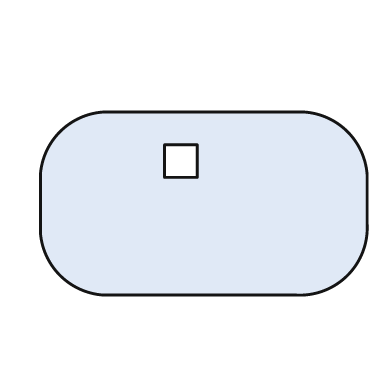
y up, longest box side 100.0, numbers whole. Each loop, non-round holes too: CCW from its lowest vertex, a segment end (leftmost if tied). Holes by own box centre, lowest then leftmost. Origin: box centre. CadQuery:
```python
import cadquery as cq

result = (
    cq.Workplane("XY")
    .moveTo(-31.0, -28.0)
    .lineTo(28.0, -28.0)
    .threePointArc((44.0, -22.0), (50.0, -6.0))
    .lineTo(50.0, 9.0)
    .threePointArc((44.0, 22.0), (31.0, 28.0))
    .lineTo(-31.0, 28.0)
    .threePointArc((-44.0, 22.0), (-50.0, 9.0))
    .lineTo(-50.0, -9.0)
    .threePointArc((-44.0, -22.0), (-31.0, -28.0))
    .close()
    .moveTo(-12.0, 8.0)
    .lineTo(-2.0, 8.0)
    .lineTo(-2.0, 18.0)
    .lineTo(-12.0, 18.0)
    .close()
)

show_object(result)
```